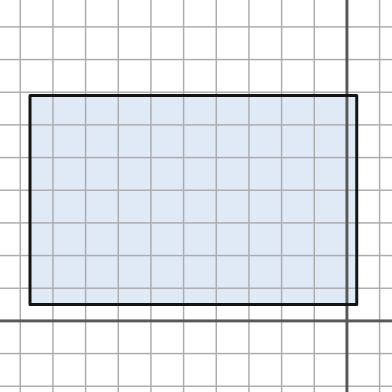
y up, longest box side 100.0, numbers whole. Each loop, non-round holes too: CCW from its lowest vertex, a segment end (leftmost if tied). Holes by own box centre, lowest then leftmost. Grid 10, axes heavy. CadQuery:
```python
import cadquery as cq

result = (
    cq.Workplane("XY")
    .moveTo(-97.0, 5.0)
    .lineTo(3.0, 5.0)
    .lineTo(3.0, 69.0)
    .lineTo(-97.0, 69.0)
    .close()
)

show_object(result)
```